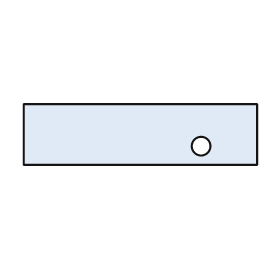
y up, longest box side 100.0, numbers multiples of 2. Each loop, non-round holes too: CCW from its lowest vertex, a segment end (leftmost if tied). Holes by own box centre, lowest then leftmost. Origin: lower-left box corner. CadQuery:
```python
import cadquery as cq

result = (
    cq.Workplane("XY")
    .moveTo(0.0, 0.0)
    .lineTo(100.0, 0.0)
    .lineTo(100.0, 26.0)
    .lineTo(0.0, 26.0)
    .close()
    .moveTo(76.0, 8.0)
    .circle(4.0)
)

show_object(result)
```